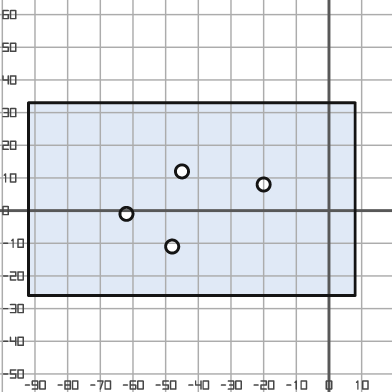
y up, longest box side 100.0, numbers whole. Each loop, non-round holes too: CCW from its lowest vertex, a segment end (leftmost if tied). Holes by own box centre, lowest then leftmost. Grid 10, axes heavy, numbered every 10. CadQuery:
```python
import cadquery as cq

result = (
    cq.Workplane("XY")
    .moveTo(-92.0, -26.0)
    .lineTo(8.0, -26.0)
    .lineTo(8.0, 33.0)
    .lineTo(-92.0, 33.0)
    .close()
    .moveTo(-48.0, -11.0)
    .circle(2.0)
    .moveTo(-62.0, -1.0)
    .circle(2.0)
    .moveTo(-20.0, 8.0)
    .circle(2.0)
    .moveTo(-45.0, 12.0)
    .circle(2.0)
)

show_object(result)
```